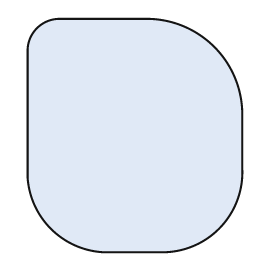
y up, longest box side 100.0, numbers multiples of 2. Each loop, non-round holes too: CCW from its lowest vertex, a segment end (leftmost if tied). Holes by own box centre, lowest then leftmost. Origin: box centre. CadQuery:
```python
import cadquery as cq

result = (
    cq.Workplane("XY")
    .moveTo(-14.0, -50.0)
    .lineTo(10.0, -50.0)
    .threePointArc((36.0, -40.0), (46.0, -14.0))
    .lineTo(46.0, 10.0)
    .threePointArc((34.0, 38.0), (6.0, 50.0))
    .lineTo(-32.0, 50.0)
    .threePointArc((-42.0, 46.0), (-46.0, 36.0))
    .lineTo(-46.0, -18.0)
    .threePointArc((-36.0, -40.0), (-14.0, -50.0))
    .close()
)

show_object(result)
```